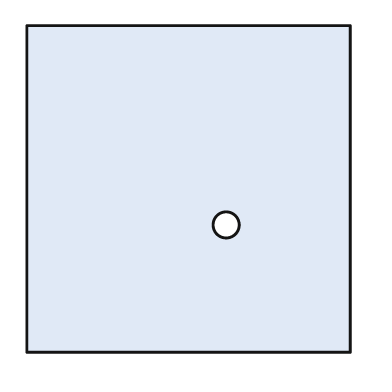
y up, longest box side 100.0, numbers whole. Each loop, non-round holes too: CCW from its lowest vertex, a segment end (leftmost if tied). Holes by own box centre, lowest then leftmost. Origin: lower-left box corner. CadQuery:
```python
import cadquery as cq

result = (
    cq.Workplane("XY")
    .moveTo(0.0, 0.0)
    .lineTo(99.0, 0.0)
    .lineTo(99.0, 100.0)
    .lineTo(0.0, 100.0)
    .close()
    .moveTo(61.0, 39.0)
    .circle(4.0)
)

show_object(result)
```